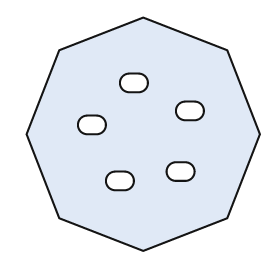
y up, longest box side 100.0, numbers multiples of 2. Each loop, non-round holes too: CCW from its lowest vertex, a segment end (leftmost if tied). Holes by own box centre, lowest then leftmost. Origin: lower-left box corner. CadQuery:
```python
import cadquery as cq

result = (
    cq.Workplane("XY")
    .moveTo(50.0, 0.0)
    .lineTo(86.0, 14.0)
    .lineTo(100.0, 50.0)
    .lineTo(86.0, 86.0)
    .lineTo(50.0, 100.0)
    .lineTo(14.0, 86.0)
    .lineTo(0.0, 50.0)
    .lineTo(14.0, 14.0)
    .close()
    .moveTo(38.0, 26.0)
    .lineTo(42.0, 26.0)
    .threePointArc((46.0, 30.0), (42.0, 34.0))
    .lineTo(38.0, 34.0)
    .threePointArc((34.0, 30.0), (38.0, 26.0))
    .close()
    .moveTo(64.0, 30.0)
    .lineTo(68.0, 30.0)
    .threePointArc((72.0, 34.0), (68.0, 38.0))
    .lineTo(64.0, 38.0)
    .threePointArc((60.0, 34.0), (64.0, 30.0))
    .close()
    .moveTo(26.0, 50.0)
    .lineTo(30.0, 50.0)
    .threePointArc((34.0, 54.0), (30.0, 58.0))
    .lineTo(26.0, 58.0)
    .threePointArc((22.0, 54.0), (26.0, 50.0))
    .close()
    .moveTo(68.0, 56.0)
    .lineTo(72.0, 56.0)
    .threePointArc((76.0, 60.0), (72.0, 64.0))
    .lineTo(68.0, 64.0)
    .threePointArc((64.0, 60.0), (68.0, 56.0))
    .close()
    .moveTo(44.0, 68.0)
    .lineTo(48.0, 68.0)
    .threePointArc((52.0, 72.0), (48.0, 76.0))
    .lineTo(44.0, 76.0)
    .threePointArc((40.0, 72.0), (44.0, 68.0))
    .close()
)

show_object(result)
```